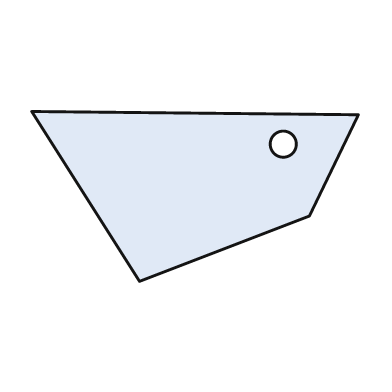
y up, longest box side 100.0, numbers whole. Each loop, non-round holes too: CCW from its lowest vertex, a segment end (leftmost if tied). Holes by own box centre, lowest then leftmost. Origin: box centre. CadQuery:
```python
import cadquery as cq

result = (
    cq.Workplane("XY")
    .moveTo(-17.0, -26.0)
    .lineTo(35.0, -6.0)
    .lineTo(50.0, 25.0)
    .lineTo(-50.0, 26.0)
    .close()
    .moveTo(27.0, 16.0)
    .circle(4.0)
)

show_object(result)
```